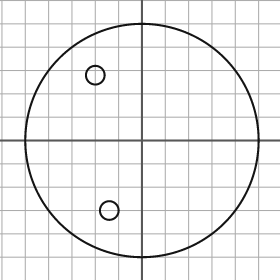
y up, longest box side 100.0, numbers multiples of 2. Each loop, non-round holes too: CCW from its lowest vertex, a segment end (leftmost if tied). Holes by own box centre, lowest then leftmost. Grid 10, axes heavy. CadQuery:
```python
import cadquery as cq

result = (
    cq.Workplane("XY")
    .moveTo(0.0, 0.0)
    .circle(50.0)
    .moveTo(-14.0, -30.0)
    .circle(4.0)
    .moveTo(-20.0, 28.0)
    .circle(4.0)
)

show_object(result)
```